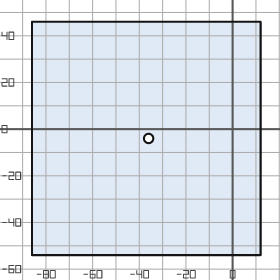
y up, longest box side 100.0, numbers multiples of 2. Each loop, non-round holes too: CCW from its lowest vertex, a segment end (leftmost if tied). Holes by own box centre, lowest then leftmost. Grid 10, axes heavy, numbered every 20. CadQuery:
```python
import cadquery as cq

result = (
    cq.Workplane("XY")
    .moveTo(-86.0, -54.0)
    .lineTo(12.0, -54.0)
    .lineTo(12.0, 46.0)
    .lineTo(-86.0, 46.0)
    .close()
    .moveTo(-36.0, -4.0)
    .circle(2.0)
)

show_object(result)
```